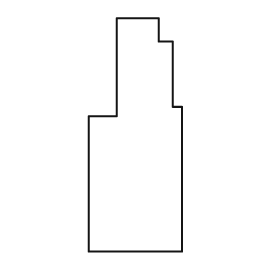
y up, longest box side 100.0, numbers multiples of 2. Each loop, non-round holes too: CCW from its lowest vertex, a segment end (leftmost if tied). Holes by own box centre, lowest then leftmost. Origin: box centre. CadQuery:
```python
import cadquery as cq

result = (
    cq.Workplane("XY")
    .moveTo(-20.0, -50.0)
    .lineTo(20.0, -50.0)
    .lineTo(20.0, 12.0)
    .lineTo(16.0, 12.0)
    .lineTo(16.0, 40.0)
    .lineTo(10.0, 40.0)
    .lineTo(10.0, 50.0)
    .lineTo(-8.0, 50.0)
    .lineTo(-8.0, 8.0)
    .lineTo(-20.0, 8.0)
    .close()
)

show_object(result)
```